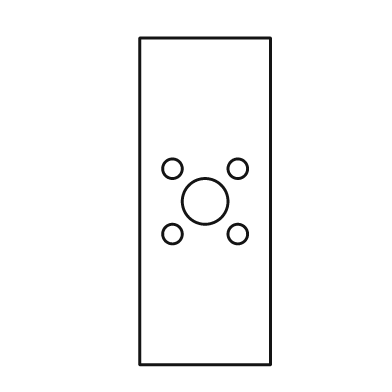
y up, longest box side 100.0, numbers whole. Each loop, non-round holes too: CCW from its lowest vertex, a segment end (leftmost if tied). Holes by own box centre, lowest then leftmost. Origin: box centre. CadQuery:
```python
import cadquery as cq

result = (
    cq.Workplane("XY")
    .moveTo(-20.0, -50.0)
    .lineTo(20.0, -50.0)
    .lineTo(20.0, 50.0)
    .lineTo(-20.0, 50.0)
    .close()
    .moveTo(-10.0, -10.0)
    .circle(3.0)
    .moveTo(10.0, -10.0)
    .circle(3.0)
    .moveTo(0.0, 0.0)
    .circle(7.0)
    .moveTo(-10.0, 10.0)
    .circle(3.0)
    .moveTo(10.0, 10.0)
    .circle(3.0)
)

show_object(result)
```